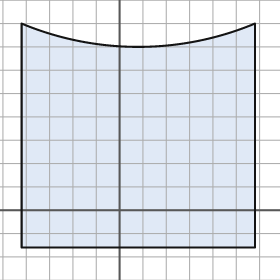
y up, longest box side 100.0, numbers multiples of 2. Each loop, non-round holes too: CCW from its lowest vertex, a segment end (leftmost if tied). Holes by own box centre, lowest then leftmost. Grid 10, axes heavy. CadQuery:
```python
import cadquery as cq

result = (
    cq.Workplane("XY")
    .moveTo(-42.0, -16.0)
    .lineTo(58.0, -16.0)
    .lineTo(58.0, 80.0)
    .threePointArc((8.0, 70.0), (-42.0, 80.0))
    .close()
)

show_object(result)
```